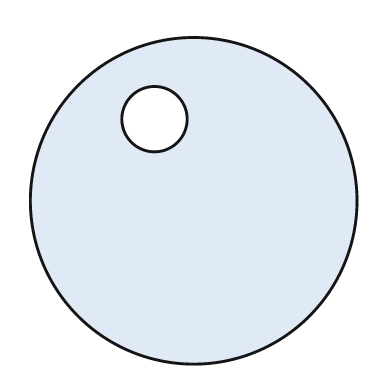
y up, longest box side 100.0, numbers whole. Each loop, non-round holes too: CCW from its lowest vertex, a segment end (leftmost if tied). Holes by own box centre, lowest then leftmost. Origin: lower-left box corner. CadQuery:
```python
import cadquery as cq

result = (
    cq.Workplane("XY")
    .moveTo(50.0, 50.0)
    .circle(50.0)
    .moveTo(38.0, 75.0)
    .circle(10.0)
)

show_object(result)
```